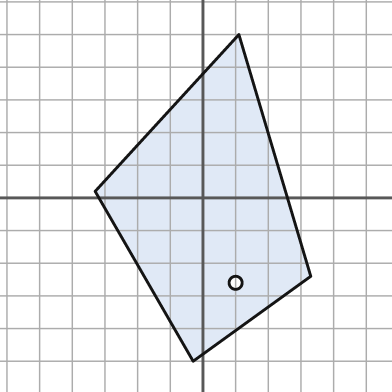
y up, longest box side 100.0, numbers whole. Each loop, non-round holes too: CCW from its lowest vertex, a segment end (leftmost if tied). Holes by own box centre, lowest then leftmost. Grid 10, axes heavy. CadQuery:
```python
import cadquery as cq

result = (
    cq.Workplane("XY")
    .moveTo(-3.0, -50.0)
    .lineTo(33.0, -24.0)
    .lineTo(11.0, 50.0)
    .lineTo(-33.0, 2.0)
    .close()
    .moveTo(10.0, -26.0)
    .circle(2.0)
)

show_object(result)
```